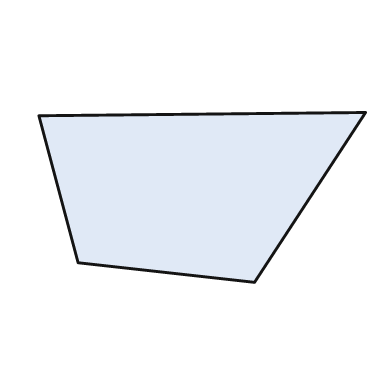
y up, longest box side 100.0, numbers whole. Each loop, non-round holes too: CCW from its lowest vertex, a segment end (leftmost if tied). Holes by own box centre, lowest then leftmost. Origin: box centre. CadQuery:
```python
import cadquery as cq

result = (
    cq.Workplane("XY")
    .moveTo(16.0, -26.0)
    .lineTo(50.0, 26.0)
    .lineTo(-50.0, 25.0)
    .lineTo(-38.0, -20.0)
    .close()
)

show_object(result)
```